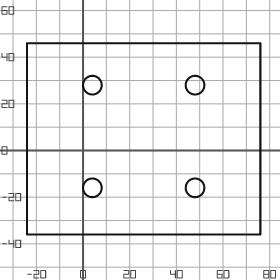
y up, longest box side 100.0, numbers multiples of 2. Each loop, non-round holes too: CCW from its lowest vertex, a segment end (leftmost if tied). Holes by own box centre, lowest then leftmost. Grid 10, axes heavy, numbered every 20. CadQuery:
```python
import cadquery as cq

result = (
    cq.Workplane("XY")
    .moveTo(-24.0, -36.0)
    .lineTo(76.0, -36.0)
    .lineTo(76.0, 46.0)
    .lineTo(-24.0, 46.0)
    .close()
    .moveTo(4.0, -16.0)
    .circle(4.0)
    .moveTo(48.0, -16.0)
    .circle(4.0)
    .moveTo(4.0, 28.0)
    .circle(4.0)
    .moveTo(48.0, 28.0)
    .circle(4.0)
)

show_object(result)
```